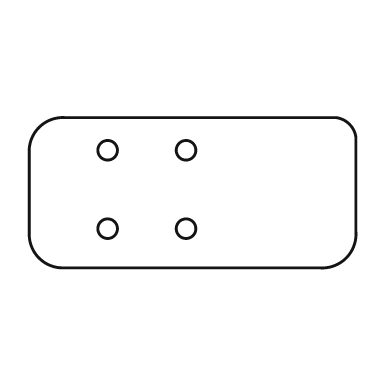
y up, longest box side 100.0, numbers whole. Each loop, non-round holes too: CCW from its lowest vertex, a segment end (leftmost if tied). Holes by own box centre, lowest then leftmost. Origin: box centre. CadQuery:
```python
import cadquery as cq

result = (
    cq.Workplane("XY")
    .moveTo(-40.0, -23.0)
    .lineTo(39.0, -23.0)
    .threePointArc((47.0, -20.0), (50.0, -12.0))
    .lineTo(50.0, 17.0)
    .threePointArc((48.0, 21.0), (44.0, 23.0))
    .lineTo(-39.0, 23.0)
    .threePointArc((-47.0, 20.0), (-50.0, 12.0))
    .lineTo(-50.0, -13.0)
    .threePointArc((-47.0, -20.0), (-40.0, -23.0))
    .close()
    .moveTo(-26.0, -11.0)
    .circle(3.0)
    .moveTo(-2.0, -11.0)
    .circle(3.0)
    .moveTo(-26.0, 13.0)
    .circle(3.0)
    .moveTo(-2.0, 13.0)
    .circle(3.0)
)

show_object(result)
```